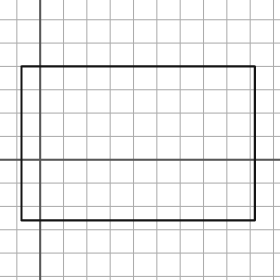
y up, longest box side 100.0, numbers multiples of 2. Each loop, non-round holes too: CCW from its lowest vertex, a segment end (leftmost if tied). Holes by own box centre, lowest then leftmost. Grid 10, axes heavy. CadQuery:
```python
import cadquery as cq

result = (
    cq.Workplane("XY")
    .moveTo(-8.0, -26.0)
    .lineTo(92.0, -26.0)
    .lineTo(92.0, 40.0)
    .lineTo(-8.0, 40.0)
    .close()
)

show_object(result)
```